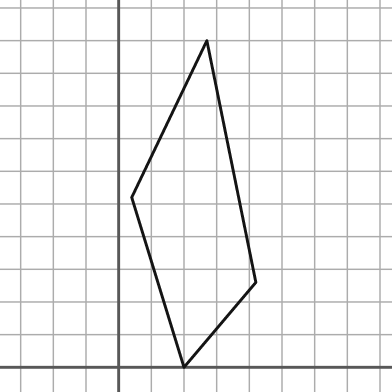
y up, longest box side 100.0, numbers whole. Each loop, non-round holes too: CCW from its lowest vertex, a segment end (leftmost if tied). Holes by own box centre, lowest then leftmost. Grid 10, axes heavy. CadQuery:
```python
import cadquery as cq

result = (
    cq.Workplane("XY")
    .moveTo(20.0, 0.0)
    .lineTo(42.0, 26.0)
    .lineTo(27.0, 100.0)
    .lineTo(4.0, 52.0)
    .close()
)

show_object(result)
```